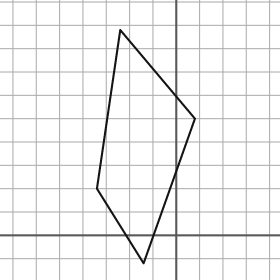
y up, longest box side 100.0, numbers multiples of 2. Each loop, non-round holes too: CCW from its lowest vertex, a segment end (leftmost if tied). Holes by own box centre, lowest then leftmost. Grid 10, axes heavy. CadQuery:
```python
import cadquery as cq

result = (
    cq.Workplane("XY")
    .moveTo(-14.0, -12.0)
    .lineTo(8.0, 50.0)
    .lineTo(-24.0, 88.0)
    .lineTo(-34.0, 20.0)
    .close()
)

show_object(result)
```